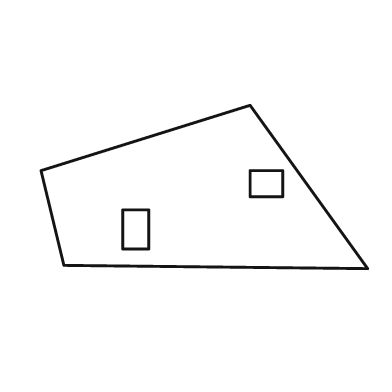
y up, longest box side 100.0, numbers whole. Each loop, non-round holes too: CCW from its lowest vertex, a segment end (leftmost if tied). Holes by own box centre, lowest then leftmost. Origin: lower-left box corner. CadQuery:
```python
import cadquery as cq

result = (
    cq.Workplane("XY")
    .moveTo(100.0, 0.0)
    .lineTo(64.0, 50.0)
    .lineTo(0.0, 30.0)
    .lineTo(7.0, 1.0)
    .close()
    .moveTo(25.0, 6.0)
    .lineTo(33.0, 6.0)
    .lineTo(33.0, 18.0)
    .lineTo(25.0, 18.0)
    .close()
    .moveTo(64.0, 22.0)
    .lineTo(74.0, 22.0)
    .lineTo(74.0, 30.0)
    .lineTo(64.0, 30.0)
    .close()
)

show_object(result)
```